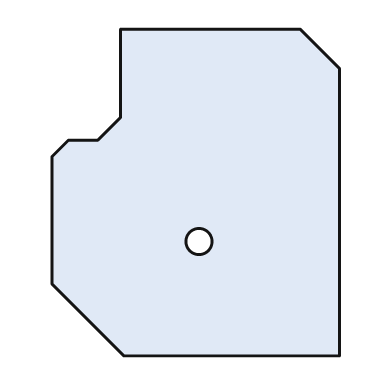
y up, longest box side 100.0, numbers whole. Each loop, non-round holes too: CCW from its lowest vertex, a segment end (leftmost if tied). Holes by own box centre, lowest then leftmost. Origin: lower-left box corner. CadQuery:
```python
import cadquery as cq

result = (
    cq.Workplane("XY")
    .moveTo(22.0, 0.0)
    .lineTo(88.0, 0.0)
    .lineTo(88.0, 88.0)
    .lineTo(76.0, 100.0)
    .lineTo(21.0, 100.0)
    .lineTo(21.0, 73.0)
    .lineTo(14.0, 66.0)
    .lineTo(5.0, 66.0)
    .lineTo(0.0, 61.0)
    .lineTo(0.0, 22.0)
    .close()
    .moveTo(45.0, 35.0)
    .circle(4.0)
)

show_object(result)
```